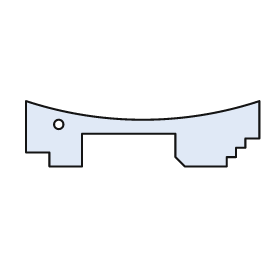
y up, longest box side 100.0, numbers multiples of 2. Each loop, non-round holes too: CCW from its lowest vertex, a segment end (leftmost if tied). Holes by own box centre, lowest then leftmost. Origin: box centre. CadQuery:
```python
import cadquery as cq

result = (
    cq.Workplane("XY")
    .moveTo(-40.0, -14.0)
    .lineTo(-26.0, -14.0)
    .lineTo(-26.0, 0.0)
    .lineTo(14.0, 0.0)
    .lineTo(14.0, -10.0)
    .lineTo(18.0, -14.0)
    .lineTo(36.0, -14.0)
    .lineTo(36.0, -10.0)
    .lineTo(40.0, -10.0)
    .lineTo(40.0, -6.0)
    .lineTo(44.0, -6.0)
    .lineTo(44.0, -2.0)
    .lineTo(50.0, -2.0)
    .lineTo(50.0, 14.0)
    .threePointArc((0.0, 6.0), (-50.0, 14.0))
    .lineTo(-50.0, -8.0)
    .lineTo(-40.0, -8.0)
    .close()
    .moveTo(-36.0, 4.0)
    .circle(2.0)
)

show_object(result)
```